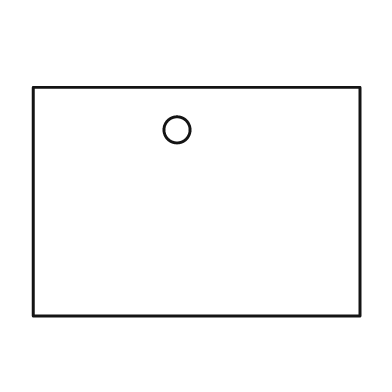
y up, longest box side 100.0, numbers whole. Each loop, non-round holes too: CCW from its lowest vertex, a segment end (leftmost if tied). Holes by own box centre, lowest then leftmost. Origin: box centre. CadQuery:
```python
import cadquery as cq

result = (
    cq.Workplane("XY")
    .moveTo(-50.0, -35.0)
    .lineTo(50.0, -35.0)
    .lineTo(50.0, 35.0)
    .lineTo(-50.0, 35.0)
    .close()
    .moveTo(-6.0, 22.0)
    .circle(4.0)
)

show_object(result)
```